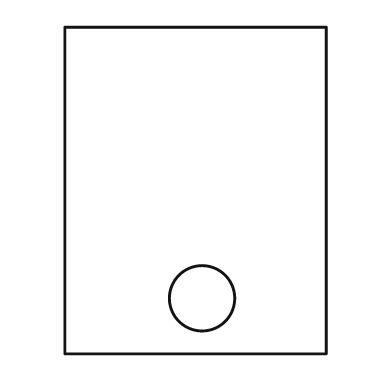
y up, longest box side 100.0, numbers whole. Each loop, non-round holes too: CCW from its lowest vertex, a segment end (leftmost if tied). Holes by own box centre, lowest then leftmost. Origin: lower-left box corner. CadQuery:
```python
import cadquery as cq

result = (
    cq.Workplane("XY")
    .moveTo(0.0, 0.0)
    .lineTo(80.0, 0.0)
    .lineTo(80.0, 100.0)
    .lineTo(0.0, 100.0)
    .close()
    .moveTo(42.0, 17.0)
    .circle(10.0)
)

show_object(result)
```